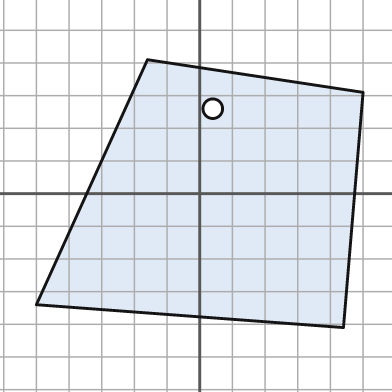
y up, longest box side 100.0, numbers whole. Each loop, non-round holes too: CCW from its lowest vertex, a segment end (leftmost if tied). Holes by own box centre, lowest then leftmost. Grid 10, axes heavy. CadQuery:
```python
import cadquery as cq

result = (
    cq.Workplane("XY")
    .moveTo(44.0, -41.0)
    .lineTo(50.0, 31.0)
    .lineTo(-16.0, 41.0)
    .lineTo(-50.0, -34.0)
    .close()
    .moveTo(4.0, 26.0)
    .circle(3.0)
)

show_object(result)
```